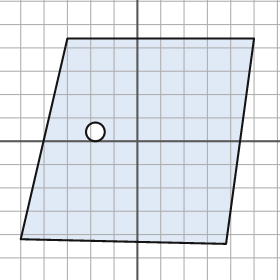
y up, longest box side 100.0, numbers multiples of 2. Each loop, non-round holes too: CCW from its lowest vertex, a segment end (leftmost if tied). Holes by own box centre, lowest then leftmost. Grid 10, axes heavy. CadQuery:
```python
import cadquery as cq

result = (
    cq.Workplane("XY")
    .moveTo(38.0, -44.0)
    .lineTo(50.0, 44.0)
    .lineTo(-30.0, 44.0)
    .lineTo(-50.0, -42.0)
    .close()
    .moveTo(-18.0, 4.0)
    .circle(4.0)
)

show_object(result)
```